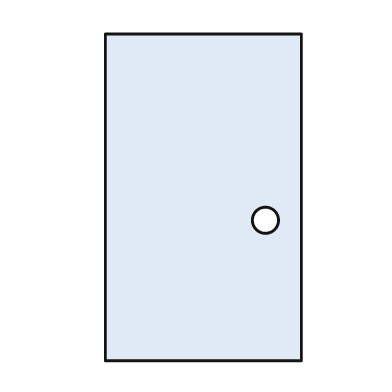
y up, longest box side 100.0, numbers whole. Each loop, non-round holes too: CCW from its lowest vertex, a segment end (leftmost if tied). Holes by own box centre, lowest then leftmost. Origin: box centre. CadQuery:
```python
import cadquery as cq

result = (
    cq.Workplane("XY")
    .moveTo(-30.0, -50.0)
    .lineTo(30.0, -50.0)
    .lineTo(30.0, 50.0)
    .lineTo(-30.0, 50.0)
    .close()
    .moveTo(19.0, -7.0)
    .circle(4.0)
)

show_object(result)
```